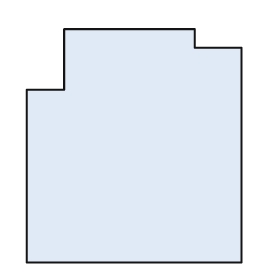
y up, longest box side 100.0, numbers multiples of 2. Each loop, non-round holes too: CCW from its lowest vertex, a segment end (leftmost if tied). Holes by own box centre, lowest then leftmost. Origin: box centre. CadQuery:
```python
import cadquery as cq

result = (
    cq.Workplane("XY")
    .moveTo(-46.0, -50.0)
    .lineTo(46.0, -50.0)
    .lineTo(46.0, 42.0)
    .lineTo(26.0, 42.0)
    .lineTo(26.0, 50.0)
    .lineTo(-30.0, 50.0)
    .lineTo(-30.0, 24.0)
    .lineTo(-46.0, 24.0)
    .close()
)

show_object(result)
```